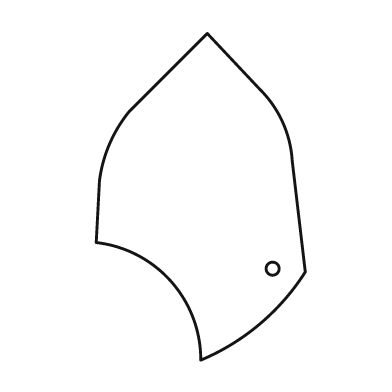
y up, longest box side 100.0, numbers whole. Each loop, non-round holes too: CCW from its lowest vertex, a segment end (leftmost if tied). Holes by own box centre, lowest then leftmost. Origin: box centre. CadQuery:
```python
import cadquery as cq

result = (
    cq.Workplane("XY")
    .moveTo(0.0, -50.0)
    .threePointArc((18.0, -39.0), (32.0, -23.0))
    .lineTo(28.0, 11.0)
    .threePointArc((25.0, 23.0), (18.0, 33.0))
    .lineTo(2.0, 50.0)
    .lineTo(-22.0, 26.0)
    .threePointArc((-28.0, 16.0), (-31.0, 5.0))
    .lineTo(-32.0, -14.0)
    .threePointArc((-9.0, -26.0), (0.0, -50.0))
    .close()
    .moveTo(22.0, -22.0)
    .circle(2.0)
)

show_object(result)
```